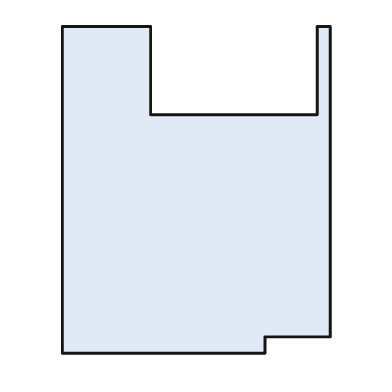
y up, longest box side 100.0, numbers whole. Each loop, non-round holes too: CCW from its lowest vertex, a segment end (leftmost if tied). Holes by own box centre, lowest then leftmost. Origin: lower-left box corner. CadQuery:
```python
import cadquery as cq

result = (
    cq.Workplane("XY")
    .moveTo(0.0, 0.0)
    .lineTo(62.0, 0.0)
    .lineTo(62.0, 5.0)
    .lineTo(82.0, 5.0)
    .lineTo(82.0, 100.0)
    .lineTo(78.0, 100.0)
    .lineTo(78.0, 73.0)
    .lineTo(27.0, 73.0)
    .lineTo(27.0, 100.0)
    .lineTo(0.0, 100.0)
    .close()
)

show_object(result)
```